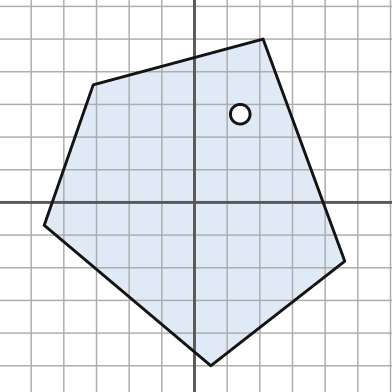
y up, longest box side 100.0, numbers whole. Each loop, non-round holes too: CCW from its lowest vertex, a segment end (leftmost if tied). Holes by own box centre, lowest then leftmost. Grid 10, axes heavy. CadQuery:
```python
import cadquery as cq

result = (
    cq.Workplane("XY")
    .moveTo(5.0, -50.0)
    .lineTo(46.0, -18.0)
    .lineTo(21.0, 50.0)
    .lineTo(-31.0, 36.0)
    .lineTo(-46.0, -7.0)
    .close()
    .moveTo(14.0, 27.0)
    .circle(3.0)
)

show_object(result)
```